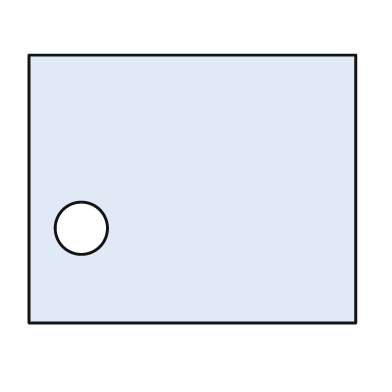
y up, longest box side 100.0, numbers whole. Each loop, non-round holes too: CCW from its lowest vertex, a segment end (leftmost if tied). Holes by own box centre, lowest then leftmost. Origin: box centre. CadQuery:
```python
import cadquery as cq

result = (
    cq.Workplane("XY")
    .moveTo(-50.0, -41.0)
    .lineTo(50.0, -41.0)
    .lineTo(50.0, 41.0)
    .lineTo(-50.0, 41.0)
    .close()
    .moveTo(-34.0, -12.0)
    .circle(8.0)
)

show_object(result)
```